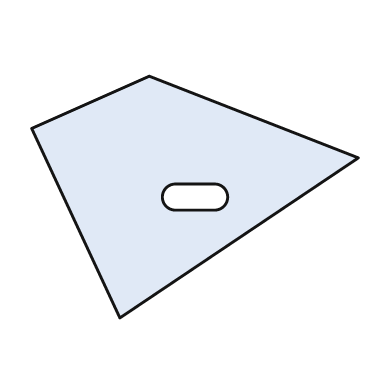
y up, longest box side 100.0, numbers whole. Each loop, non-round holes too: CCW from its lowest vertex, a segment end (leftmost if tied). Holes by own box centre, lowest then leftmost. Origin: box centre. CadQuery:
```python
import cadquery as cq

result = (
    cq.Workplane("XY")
    .moveTo(-23.0, -37.0)
    .lineTo(50.0, 12.0)
    .lineTo(-14.0, 37.0)
    .lineTo(-50.0, 21.0)
    .close()
    .moveTo(-6.0, -4.0)
    .lineTo(6.0, -4.0)
    .threePointArc((10.0, 0.0), (6.0, 4.0))
    .lineTo(-6.0, 4.0)
    .threePointArc((-10.0, 0.0), (-6.0, -4.0))
    .close()
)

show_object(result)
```